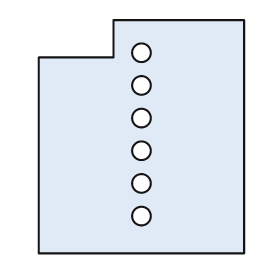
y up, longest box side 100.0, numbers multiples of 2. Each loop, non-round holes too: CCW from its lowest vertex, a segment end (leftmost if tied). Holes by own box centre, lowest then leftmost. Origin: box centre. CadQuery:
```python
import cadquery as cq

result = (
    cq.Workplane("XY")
    .moveTo(-44.0, -50.0)
    .lineTo(44.0, -50.0)
    .lineTo(44.0, 50.0)
    .lineTo(-12.0, 50.0)
    .lineTo(-12.0, 34.0)
    .lineTo(-44.0, 34.0)
    .close()
    .moveTo(0.0, -34.0)
    .circle(4.0)
    .moveTo(0.0, -20.0)
    .circle(4.0)
    .moveTo(0.0, -6.0)
    .circle(4.0)
    .moveTo(0.0, 8.0)
    .circle(4.0)
    .moveTo(0.0, 22.0)
    .circle(4.0)
    .moveTo(0.0, 36.0)
    .circle(4.0)
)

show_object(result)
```